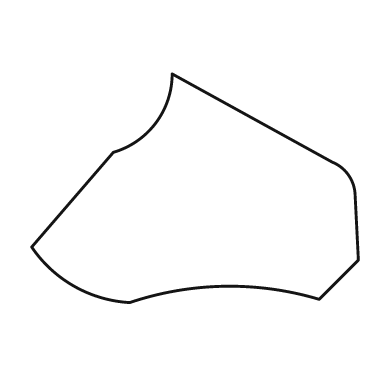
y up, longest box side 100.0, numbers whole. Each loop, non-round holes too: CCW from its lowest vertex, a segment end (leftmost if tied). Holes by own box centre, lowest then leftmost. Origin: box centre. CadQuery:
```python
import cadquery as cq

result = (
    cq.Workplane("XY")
    .moveTo(-20.0, -35.0)
    .threePointArc((9.0, -30.0), (38.0, -34.0))
    .lineTo(50.0, -22.0)
    .lineTo(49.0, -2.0)
    .threePointArc((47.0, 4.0), (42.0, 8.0))
    .lineTo(-7.0, 35.0)
    .threePointArc((-12.0, 20.0), (-25.0, 11.0))
    .lineTo(-50.0, -18.0)
    .threePointArc((-37.0, -30.0), (-20.0, -35.0))
    .close()
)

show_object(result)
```